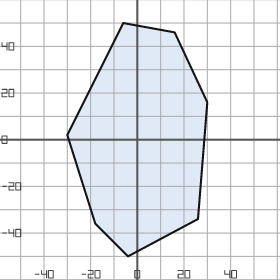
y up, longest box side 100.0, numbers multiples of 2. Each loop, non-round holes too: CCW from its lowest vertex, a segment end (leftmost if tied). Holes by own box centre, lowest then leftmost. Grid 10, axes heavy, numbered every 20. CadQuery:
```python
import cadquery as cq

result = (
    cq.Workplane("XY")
    .moveTo(-4.0, -50.0)
    .lineTo(26.0, -34.0)
    .lineTo(30.0, 16.0)
    .lineTo(16.0, 46.0)
    .lineTo(-6.0, 50.0)
    .lineTo(-30.0, 2.0)
    .lineTo(-18.0, -36.0)
    .close()
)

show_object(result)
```